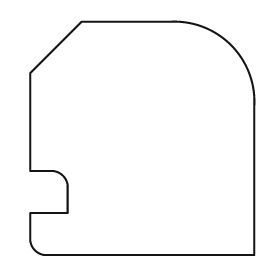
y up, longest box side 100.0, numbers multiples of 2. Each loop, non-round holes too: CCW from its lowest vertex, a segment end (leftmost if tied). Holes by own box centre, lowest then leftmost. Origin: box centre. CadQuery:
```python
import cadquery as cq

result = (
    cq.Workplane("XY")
    .moveTo(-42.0, -50.0)
    .lineTo(48.0, -50.0)
    .lineTo(48.0, 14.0)
    .threePointArc((38.0, 40.0), (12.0, 50.0))
    .lineTo(-26.0, 50.0)
    .lineTo(-48.0, 28.0)
    .lineTo(-48.0, -14.0)
    .lineTo(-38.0, -14.0)
    .threePointArc((-34.0, -16.0), (-32.0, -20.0))
    .lineTo(-32.0, -32.0)
    .lineTo(-48.0, -32.0)
    .lineTo(-48.0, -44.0)
    .threePointArc((-46.0, -48.0), (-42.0, -50.0))
    .close()
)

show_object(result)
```